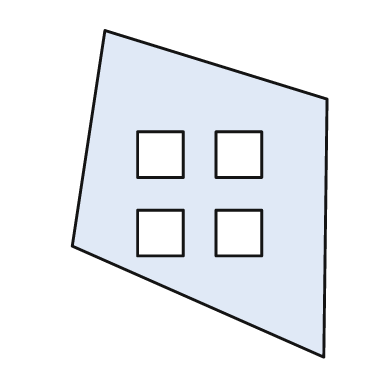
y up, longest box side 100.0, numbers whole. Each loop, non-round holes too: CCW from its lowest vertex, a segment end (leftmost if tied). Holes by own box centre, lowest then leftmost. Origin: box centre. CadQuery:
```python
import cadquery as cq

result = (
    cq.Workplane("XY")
    .moveTo(38.0, -50.0)
    .lineTo(39.0, 29.0)
    .lineTo(-29.0, 50.0)
    .lineTo(-39.0, -16.0)
    .close()
    .moveTo(-19.0, -19.0)
    .lineTo(-5.0, -19.0)
    .lineTo(-5.0, -5.0)
    .lineTo(-19.0, -5.0)
    .close()
    .moveTo(5.0, -19.0)
    .lineTo(19.0, -19.0)
    .lineTo(19.0, -5.0)
    .lineTo(5.0, -5.0)
    .close()
    .moveTo(-19.0, 5.0)
    .lineTo(-5.0, 5.0)
    .lineTo(-5.0, 19.0)
    .lineTo(-19.0, 19.0)
    .close()
    .moveTo(5.0, 5.0)
    .lineTo(19.0, 5.0)
    .lineTo(19.0, 19.0)
    .lineTo(5.0, 19.0)
    .close()
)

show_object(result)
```